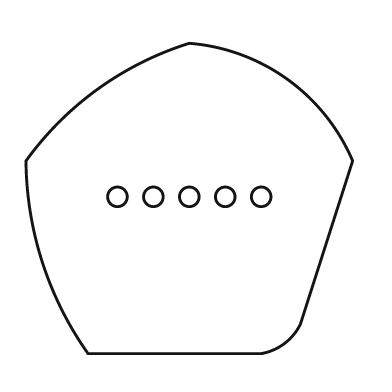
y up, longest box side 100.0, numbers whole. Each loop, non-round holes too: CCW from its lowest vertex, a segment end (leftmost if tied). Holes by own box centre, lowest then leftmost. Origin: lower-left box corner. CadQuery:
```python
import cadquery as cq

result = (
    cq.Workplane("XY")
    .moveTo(19.0, 0.0)
    .lineTo(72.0, 0.0)
    .threePointArc((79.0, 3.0), (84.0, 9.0))
    .lineTo(100.0, 59.0)
    .threePointArc((80.0, 84.0), (50.0, 95.0))
    .threePointArc((22.0, 81.0), (0.0, 59.0))
    .threePointArc((5.0, 28.0), (19.0, 0.0))
    .close()
    .moveTo(28.0, 48.0)
    .circle(3.0)
    .moveTo(39.0, 48.0)
    .circle(3.0)
    .moveTo(50.0, 48.0)
    .circle(3.0)
    .moveTo(61.0, 48.0)
    .circle(3.0)
    .moveTo(72.0, 48.0)
    .circle(3.0)
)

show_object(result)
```